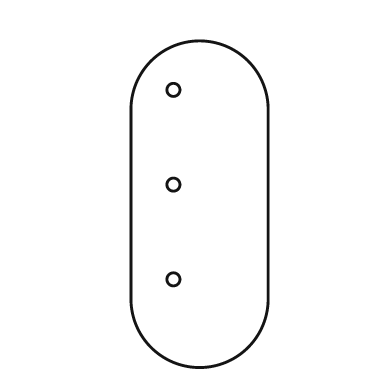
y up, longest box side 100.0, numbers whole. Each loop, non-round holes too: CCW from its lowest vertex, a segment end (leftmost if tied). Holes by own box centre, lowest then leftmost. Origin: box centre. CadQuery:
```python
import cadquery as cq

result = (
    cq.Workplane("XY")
    .moveTo(-21.0, -29.0)
    .threePointArc((0.0, -50.0), (21.0, -29.0))
    .lineTo(21.0, 29.0)
    .threePointArc((0.0, 50.0), (-21.0, 29.0))
    .close()
    .moveTo(-8.0, -23.0)
    .circle(2.0)
    .moveTo(-8.0, 6.0)
    .circle(2.0)
    .moveTo(-8.0, 35.0)
    .circle(2.0)
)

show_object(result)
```